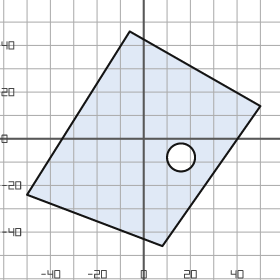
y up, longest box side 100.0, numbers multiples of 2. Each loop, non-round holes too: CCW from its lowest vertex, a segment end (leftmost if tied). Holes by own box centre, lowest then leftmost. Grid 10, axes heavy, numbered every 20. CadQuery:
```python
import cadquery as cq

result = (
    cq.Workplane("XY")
    .moveTo(8.0, -46.0)
    .lineTo(50.0, 14.0)
    .lineTo(-6.0, 46.0)
    .lineTo(-50.0, -24.0)
    .close()
    .moveTo(16.0, -8.0)
    .circle(6.0)
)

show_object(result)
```